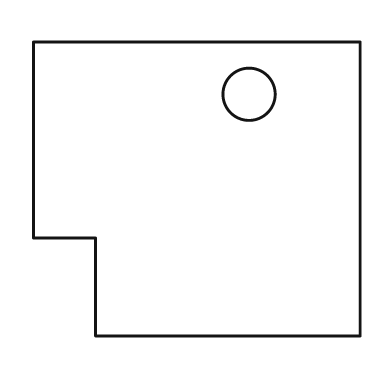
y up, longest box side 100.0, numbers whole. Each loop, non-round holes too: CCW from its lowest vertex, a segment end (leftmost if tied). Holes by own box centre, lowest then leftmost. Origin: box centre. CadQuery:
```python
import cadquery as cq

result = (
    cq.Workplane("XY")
    .moveTo(-31.0, -45.0)
    .lineTo(50.0, -45.0)
    .lineTo(50.0, 45.0)
    .lineTo(-50.0, 45.0)
    .lineTo(-50.0, -15.0)
    .lineTo(-31.0, -15.0)
    .close()
    .moveTo(16.0, 29.0)
    .circle(8.0)
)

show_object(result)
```